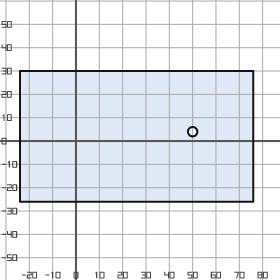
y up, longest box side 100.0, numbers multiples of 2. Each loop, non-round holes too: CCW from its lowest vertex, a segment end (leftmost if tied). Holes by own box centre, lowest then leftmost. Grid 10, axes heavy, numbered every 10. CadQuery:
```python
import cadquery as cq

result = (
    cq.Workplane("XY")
    .moveTo(-24.0, -26.0)
    .lineTo(76.0, -26.0)
    .lineTo(76.0, 30.0)
    .lineTo(-24.0, 30.0)
    .close()
    .moveTo(50.0, 4.0)
    .circle(2.0)
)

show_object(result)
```